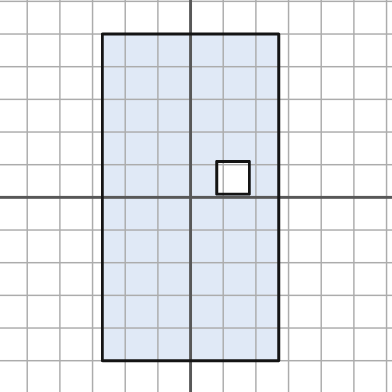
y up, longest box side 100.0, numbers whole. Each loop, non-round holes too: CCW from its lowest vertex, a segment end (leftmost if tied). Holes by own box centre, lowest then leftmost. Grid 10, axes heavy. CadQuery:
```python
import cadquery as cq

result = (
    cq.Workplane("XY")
    .moveTo(-27.0, -50.0)
    .lineTo(27.0, -50.0)
    .lineTo(27.0, 50.0)
    .lineTo(-27.0, 50.0)
    .close()
    .moveTo(8.0, 1.0)
    .lineTo(18.0, 1.0)
    .lineTo(18.0, 11.0)
    .lineTo(8.0, 11.0)
    .close()
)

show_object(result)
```